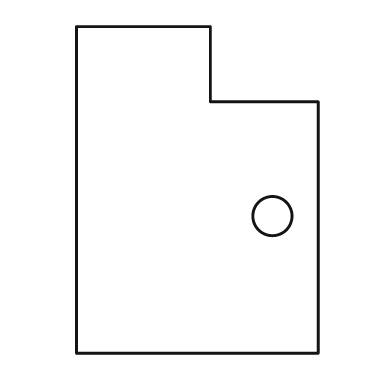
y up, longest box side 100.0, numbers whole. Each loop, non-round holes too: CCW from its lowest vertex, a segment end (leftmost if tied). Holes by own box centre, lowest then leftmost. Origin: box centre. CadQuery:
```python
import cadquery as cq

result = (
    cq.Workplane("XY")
    .moveTo(-37.0, -50.0)
    .lineTo(37.0, -50.0)
    .lineTo(37.0, 27.0)
    .lineTo(4.0, 27.0)
    .lineTo(4.0, 50.0)
    .lineTo(-37.0, 50.0)
    .close()
    .moveTo(23.0, -8.0)
    .circle(6.0)
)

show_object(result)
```